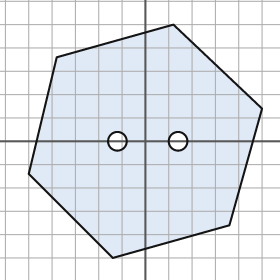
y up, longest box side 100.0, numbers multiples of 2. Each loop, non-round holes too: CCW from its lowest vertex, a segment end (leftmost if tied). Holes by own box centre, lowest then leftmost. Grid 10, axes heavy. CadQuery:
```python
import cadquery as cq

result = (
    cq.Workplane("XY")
    .moveTo(-14.0, -50.0)
    .lineTo(36.0, -36.0)
    .lineTo(50.0, 14.0)
    .lineTo(12.0, 50.0)
    .lineTo(-38.0, 36.0)
    .lineTo(-50.0, -14.0)
    .close()
    .moveTo(-12.0, 0.0)
    .circle(4.0)
    .moveTo(14.0, 0.0)
    .circle(4.0)
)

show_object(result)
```